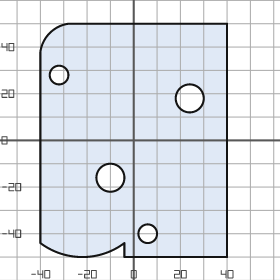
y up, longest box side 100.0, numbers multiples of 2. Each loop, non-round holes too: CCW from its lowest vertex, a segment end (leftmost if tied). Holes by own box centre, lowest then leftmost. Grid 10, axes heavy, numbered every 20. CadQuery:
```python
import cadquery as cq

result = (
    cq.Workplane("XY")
    .moveTo(-4.0, -50.0)
    .lineTo(40.0, -50.0)
    .lineTo(40.0, 50.0)
    .lineTo(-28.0, 50.0)
    .threePointArc((-36.0, 46.0), (-40.0, 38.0))
    .lineTo(-40.0, -44.0)
    .threePointArc((-22.0, -50.0), (-4.0, -44.0))
    .close()
    .moveTo(6.0, -40.0)
    .circle(4.0)
    .moveTo(-10.0, -16.0)
    .circle(6.0)
    .moveTo(24.0, 18.0)
    .circle(6.0)
    .moveTo(-32.0, 28.0)
    .circle(4.0)
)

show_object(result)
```